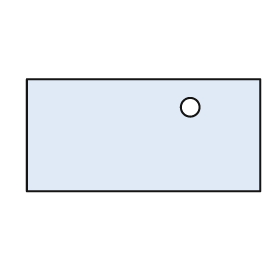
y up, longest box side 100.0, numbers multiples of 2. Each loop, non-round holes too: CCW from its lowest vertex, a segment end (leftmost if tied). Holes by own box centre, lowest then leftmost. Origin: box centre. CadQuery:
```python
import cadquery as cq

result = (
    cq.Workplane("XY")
    .moveTo(-50.0, -24.0)
    .lineTo(50.0, -24.0)
    .lineTo(50.0, 24.0)
    .lineTo(-50.0, 24.0)
    .close()
    .moveTo(20.0, 12.0)
    .circle(4.0)
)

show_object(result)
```